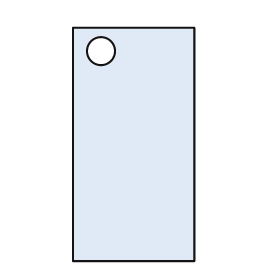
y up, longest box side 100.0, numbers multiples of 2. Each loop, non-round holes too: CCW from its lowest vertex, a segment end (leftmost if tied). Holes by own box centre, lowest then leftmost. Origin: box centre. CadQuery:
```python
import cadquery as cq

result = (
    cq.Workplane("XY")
    .moveTo(-26.0, -50.0)
    .lineTo(26.0, -50.0)
    .lineTo(26.0, 50.0)
    .lineTo(-26.0, 50.0)
    .close()
    .moveTo(-14.0, 40.0)
    .circle(6.0)
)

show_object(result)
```